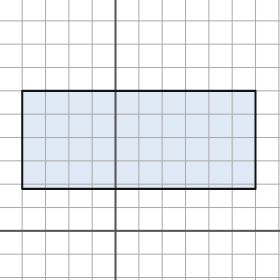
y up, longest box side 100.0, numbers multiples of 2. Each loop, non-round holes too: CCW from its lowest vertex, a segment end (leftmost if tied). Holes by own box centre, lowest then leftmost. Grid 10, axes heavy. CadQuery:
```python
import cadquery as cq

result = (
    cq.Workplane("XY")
    .moveTo(-40.0, 18.0)
    .lineTo(60.0, 18.0)
    .lineTo(60.0, 60.0)
    .lineTo(-40.0, 60.0)
    .close()
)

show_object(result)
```